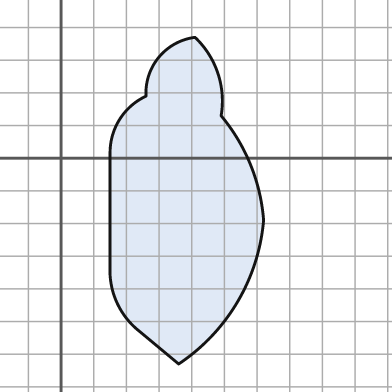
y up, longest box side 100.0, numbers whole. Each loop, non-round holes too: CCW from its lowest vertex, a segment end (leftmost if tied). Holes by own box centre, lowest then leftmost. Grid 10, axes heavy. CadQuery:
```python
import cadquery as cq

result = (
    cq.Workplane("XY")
    .moveTo(36.0, -63.0)
    .threePointArc((54.0, -44.0), (62.0, -19.0))
    .threePointArc((58.0, -2.0), (49.0, 13.0))
    .threePointArc((48.0, 26.0), (41.0, 37.0))
    .threePointArc((30.0, 31.0), (26.0, 19.0))
    .threePointArc((18.0, 12.0), (15.0, 2.0))
    .lineTo(15.0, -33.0)
    .threePointArc((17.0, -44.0), (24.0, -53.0))
    .close()
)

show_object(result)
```